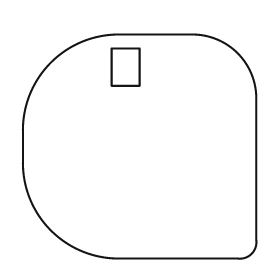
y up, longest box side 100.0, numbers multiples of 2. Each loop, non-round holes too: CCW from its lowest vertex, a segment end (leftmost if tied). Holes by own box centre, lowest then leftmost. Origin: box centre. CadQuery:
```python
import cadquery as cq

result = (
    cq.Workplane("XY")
    .moveTo(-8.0, -48.0)
    .lineTo(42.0, -48.0)
    .threePointArc((48.0, -46.0), (50.0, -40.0))
    .lineTo(50.0, 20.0)
    .threePointArc((42.0, 40.0), (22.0, 48.0))
    .lineTo(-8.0, 48.0)
    .threePointArc((-38.0, 36.0), (-50.0, 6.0))
    .lineTo(-50.0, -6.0)
    .threePointArc((-38.0, -36.0), (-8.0, -48.0))
    .close()
    .moveTo(-12.0, 26.0)
    .lineTo(0.0, 26.0)
    .lineTo(0.0, 42.0)
    .lineTo(-12.0, 42.0)
    .close()
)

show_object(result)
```